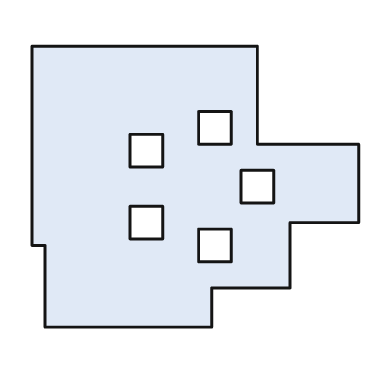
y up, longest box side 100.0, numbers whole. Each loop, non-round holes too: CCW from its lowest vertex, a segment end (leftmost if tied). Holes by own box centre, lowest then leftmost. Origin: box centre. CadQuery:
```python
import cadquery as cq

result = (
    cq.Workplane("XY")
    .moveTo(-46.0, -43.0)
    .lineTo(5.0, -43.0)
    .lineTo(5.0, -31.0)
    .lineTo(29.0, -31.0)
    .lineTo(29.0, -11.0)
    .lineTo(50.0, -11.0)
    .lineTo(50.0, 13.0)
    .lineTo(19.0, 13.0)
    .lineTo(19.0, 43.0)
    .lineTo(-50.0, 43.0)
    .lineTo(-50.0, -18.0)
    .lineTo(-46.0, -18.0)
    .close()
    .moveTo(1.0, -23.0)
    .lineTo(11.0, -23.0)
    .lineTo(11.0, -13.0)
    .lineTo(1.0, -13.0)
    .close()
    .moveTo(-20.0, -16.0)
    .lineTo(-10.0, -16.0)
    .lineTo(-10.0, -6.0)
    .lineTo(-20.0, -6.0)
    .close()
    .moveTo(14.0, -5.0)
    .lineTo(24.0, -5.0)
    .lineTo(24.0, 5.0)
    .lineTo(14.0, 5.0)
    .close()
    .moveTo(-20.0, 6.0)
    .lineTo(-10.0, 6.0)
    .lineTo(-10.0, 16.0)
    .lineTo(-20.0, 16.0)
    .close()
    .moveTo(1.0, 13.0)
    .lineTo(11.0, 13.0)
    .lineTo(11.0, 23.0)
    .lineTo(1.0, 23.0)
    .close()
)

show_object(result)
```